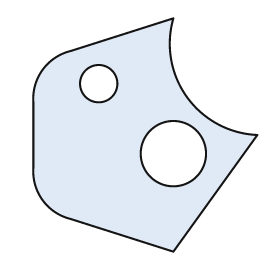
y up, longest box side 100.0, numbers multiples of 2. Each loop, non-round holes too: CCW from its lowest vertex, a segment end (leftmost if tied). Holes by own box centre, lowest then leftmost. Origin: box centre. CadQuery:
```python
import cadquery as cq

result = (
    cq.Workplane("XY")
    .moveTo(12.0, -50.0)
    .lineTo(48.0, 0.0)
    .threePointArc((18.0, 16.0), (12.0, 50.0))
    .lineTo(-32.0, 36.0)
    .threePointArc((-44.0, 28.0), (-48.0, 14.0))
    .lineTo(-48.0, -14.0)
    .threePointArc((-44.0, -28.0), (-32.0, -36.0))
    .close()
    .moveTo(12.0, -8.0)
    .circle(14.0)
    .moveTo(-20.0, 22.0)
    .circle(8.0)
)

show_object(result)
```